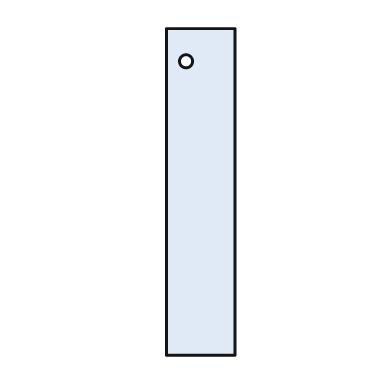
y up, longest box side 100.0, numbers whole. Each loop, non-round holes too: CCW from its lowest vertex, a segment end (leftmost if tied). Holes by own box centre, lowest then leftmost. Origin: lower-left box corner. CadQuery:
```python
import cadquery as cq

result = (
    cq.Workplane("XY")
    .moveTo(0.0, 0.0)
    .lineTo(21.0, 0.0)
    .lineTo(21.0, 100.0)
    .lineTo(0.0, 100.0)
    .close()
    .moveTo(6.0, 90.0)
    .circle(2.0)
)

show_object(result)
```